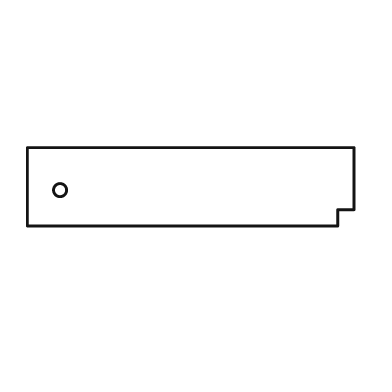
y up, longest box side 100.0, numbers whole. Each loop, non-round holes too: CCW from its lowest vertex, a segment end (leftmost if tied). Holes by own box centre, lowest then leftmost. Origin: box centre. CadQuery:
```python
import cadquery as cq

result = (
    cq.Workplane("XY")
    .moveTo(-50.0, -12.0)
    .lineTo(45.0, -12.0)
    .lineTo(45.0, -7.0)
    .lineTo(50.0, -7.0)
    .lineTo(50.0, 12.0)
    .lineTo(-50.0, 12.0)
    .close()
    .moveTo(-40.0, -1.0)
    .circle(2.0)
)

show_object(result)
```